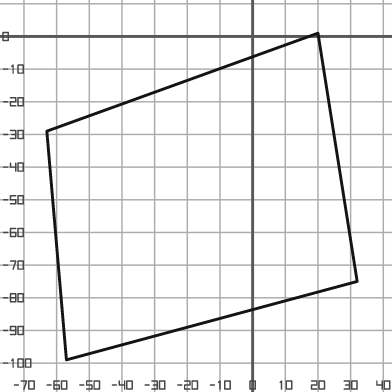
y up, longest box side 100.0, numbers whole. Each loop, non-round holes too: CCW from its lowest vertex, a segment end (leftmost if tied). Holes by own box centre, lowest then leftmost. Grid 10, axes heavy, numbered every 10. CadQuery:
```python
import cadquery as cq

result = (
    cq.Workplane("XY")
    .moveTo(-57.0, -99.0)
    .lineTo(32.0, -75.0)
    .lineTo(20.0, 1.0)
    .lineTo(-63.0, -29.0)
    .close()
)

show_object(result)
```